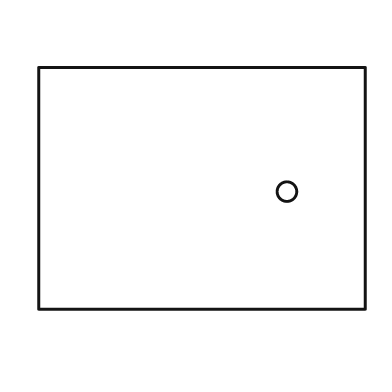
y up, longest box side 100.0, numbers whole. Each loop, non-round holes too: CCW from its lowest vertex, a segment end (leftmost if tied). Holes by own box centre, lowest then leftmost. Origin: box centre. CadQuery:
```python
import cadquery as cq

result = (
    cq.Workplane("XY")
    .moveTo(-50.0, -37.0)
    .lineTo(50.0, -37.0)
    .lineTo(50.0, 37.0)
    .lineTo(-50.0, 37.0)
    .close()
    .moveTo(26.0, -1.0)
    .circle(3.0)
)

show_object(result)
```